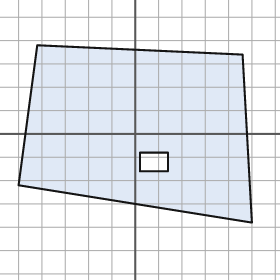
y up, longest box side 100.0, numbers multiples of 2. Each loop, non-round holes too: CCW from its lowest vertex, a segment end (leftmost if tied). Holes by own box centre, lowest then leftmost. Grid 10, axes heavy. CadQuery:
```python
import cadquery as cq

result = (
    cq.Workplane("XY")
    .moveTo(50.0, -38.0)
    .lineTo(46.0, 34.0)
    .lineTo(-42.0, 38.0)
    .lineTo(-50.0, -22.0)
    .close()
    .moveTo(2.0, -16.0)
    .lineTo(14.0, -16.0)
    .lineTo(14.0, -8.0)
    .lineTo(2.0, -8.0)
    .close()
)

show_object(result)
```